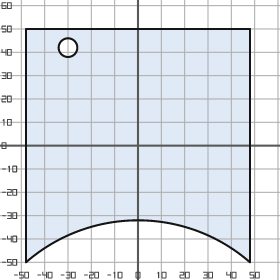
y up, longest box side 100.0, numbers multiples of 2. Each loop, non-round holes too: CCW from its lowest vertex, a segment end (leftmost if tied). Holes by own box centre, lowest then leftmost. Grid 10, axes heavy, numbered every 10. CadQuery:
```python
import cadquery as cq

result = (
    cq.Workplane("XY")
    .moveTo(-48.0, -50.0)
    .threePointArc((0.0, -32.0), (48.0, -50.0))
    .lineTo(48.0, 50.0)
    .lineTo(-48.0, 50.0)
    .close()
    .moveTo(-30.0, 42.0)
    .circle(4.0)
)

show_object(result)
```